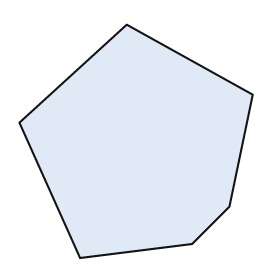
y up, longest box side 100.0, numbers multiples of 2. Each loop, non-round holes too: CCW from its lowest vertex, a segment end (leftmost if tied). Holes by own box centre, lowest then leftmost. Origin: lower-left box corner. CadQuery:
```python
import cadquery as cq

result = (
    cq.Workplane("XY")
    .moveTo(26.0, 0.0)
    .lineTo(74.0, 6.0)
    .lineTo(90.0, 22.0)
    .lineTo(100.0, 70.0)
    .lineTo(46.0, 100.0)
    .lineTo(0.0, 58.0)
    .close()
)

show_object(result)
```